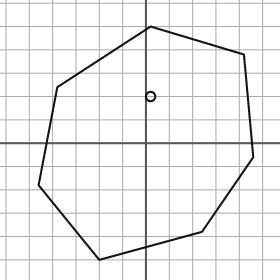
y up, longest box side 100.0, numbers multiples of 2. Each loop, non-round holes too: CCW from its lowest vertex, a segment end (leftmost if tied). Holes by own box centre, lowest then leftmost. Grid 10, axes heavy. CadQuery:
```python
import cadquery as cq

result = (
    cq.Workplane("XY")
    .moveTo(-20.0, -50.0)
    .lineTo(24.0, -38.0)
    .lineTo(46.0, -6.0)
    .lineTo(42.0, 38.0)
    .lineTo(2.0, 50.0)
    .lineTo(-38.0, 24.0)
    .lineTo(-46.0, -18.0)
    .close()
    .moveTo(2.0, 20.0)
    .circle(2.0)
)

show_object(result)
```